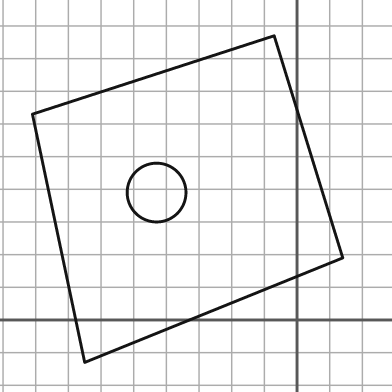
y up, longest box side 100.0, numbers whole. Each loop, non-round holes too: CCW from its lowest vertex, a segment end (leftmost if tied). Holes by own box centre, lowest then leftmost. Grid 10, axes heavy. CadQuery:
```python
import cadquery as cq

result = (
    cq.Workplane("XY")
    .moveTo(-65.0, -13.0)
    .lineTo(14.0, 19.0)
    .lineTo(-7.0, 87.0)
    .lineTo(-81.0, 63.0)
    .close()
    .moveTo(-43.0, 39.0)
    .circle(9.0)
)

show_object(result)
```